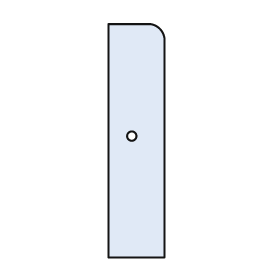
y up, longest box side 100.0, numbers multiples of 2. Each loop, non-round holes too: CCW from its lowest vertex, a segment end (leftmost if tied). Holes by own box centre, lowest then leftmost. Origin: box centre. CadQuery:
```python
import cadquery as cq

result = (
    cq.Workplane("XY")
    .moveTo(-12.0, -50.0)
    .lineTo(12.0, -50.0)
    .lineTo(12.0, 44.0)
    .threePointArc((10.0, 48.0), (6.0, 50.0))
    .lineTo(-12.0, 50.0)
    .close()
    .moveTo(-2.0, 2.0)
    .circle(2.0)
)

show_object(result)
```